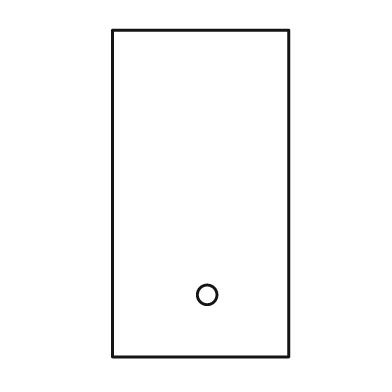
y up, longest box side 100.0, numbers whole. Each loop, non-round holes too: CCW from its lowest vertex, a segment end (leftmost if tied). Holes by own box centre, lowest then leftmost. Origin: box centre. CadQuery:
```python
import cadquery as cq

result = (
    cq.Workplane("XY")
    .moveTo(-27.0, -50.0)
    .lineTo(27.0, -50.0)
    .lineTo(27.0, 50.0)
    .lineTo(-27.0, 50.0)
    .close()
    .moveTo(2.0, -31.0)
    .circle(3.0)
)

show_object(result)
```